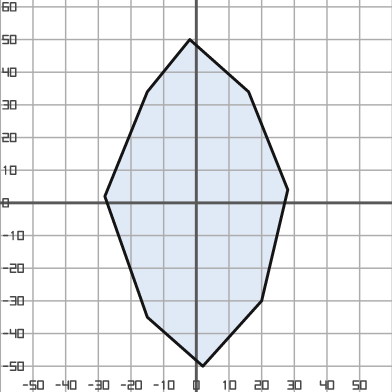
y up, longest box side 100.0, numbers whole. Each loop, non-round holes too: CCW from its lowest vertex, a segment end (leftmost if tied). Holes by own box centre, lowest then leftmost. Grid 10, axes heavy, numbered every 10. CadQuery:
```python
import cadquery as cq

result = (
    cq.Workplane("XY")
    .moveTo(2.0, -50.0)
    .lineTo(20.0, -30.0)
    .lineTo(28.0, 4.0)
    .lineTo(16.0, 34.0)
    .lineTo(-2.0, 50.0)
    .lineTo(-15.0, 34.0)
    .lineTo(-28.0, 2.0)
    .lineTo(-15.0, -35.0)
    .close()
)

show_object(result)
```